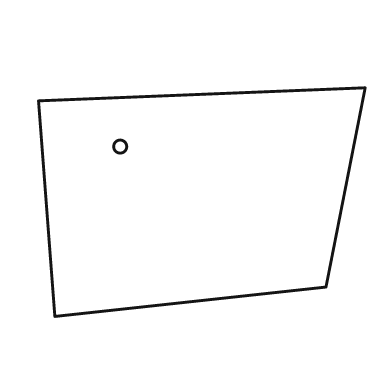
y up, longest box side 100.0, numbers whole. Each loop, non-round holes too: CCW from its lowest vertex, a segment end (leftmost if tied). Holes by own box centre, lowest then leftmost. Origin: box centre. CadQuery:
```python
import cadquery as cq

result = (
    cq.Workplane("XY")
    .moveTo(-45.0, -35.0)
    .lineTo(38.0, -26.0)
    .lineTo(50.0, 35.0)
    .lineTo(-50.0, 31.0)
    .close()
    .moveTo(-25.0, 17.0)
    .circle(2.0)
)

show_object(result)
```